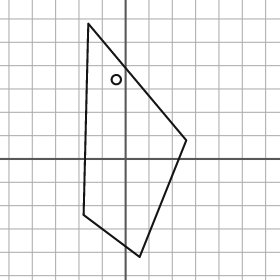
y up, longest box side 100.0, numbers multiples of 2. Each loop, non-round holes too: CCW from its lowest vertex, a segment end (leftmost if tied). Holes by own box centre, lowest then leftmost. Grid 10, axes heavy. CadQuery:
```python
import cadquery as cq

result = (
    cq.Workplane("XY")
    .moveTo(6.0, -42.0)
    .lineTo(26.0, 8.0)
    .lineTo(-16.0, 58.0)
    .lineTo(-18.0, -24.0)
    .close()
    .moveTo(-4.0, 34.0)
    .circle(2.0)
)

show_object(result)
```